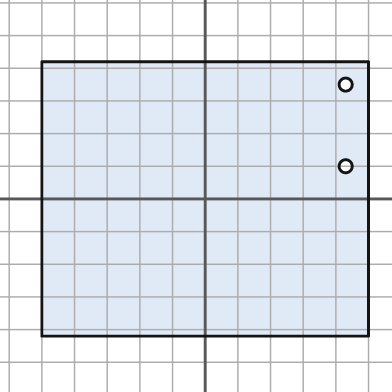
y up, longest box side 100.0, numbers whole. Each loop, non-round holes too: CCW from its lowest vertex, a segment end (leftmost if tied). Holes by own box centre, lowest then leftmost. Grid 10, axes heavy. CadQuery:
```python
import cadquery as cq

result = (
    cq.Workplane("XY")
    .moveTo(-50.0, -42.0)
    .lineTo(50.0, -42.0)
    .lineTo(50.0, 42.0)
    .lineTo(-50.0, 42.0)
    .close()
    .moveTo(43.0, 10.0)
    .circle(2.0)
    .moveTo(43.0, 35.0)
    .circle(2.0)
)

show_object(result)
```